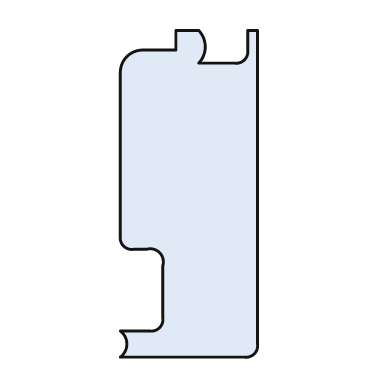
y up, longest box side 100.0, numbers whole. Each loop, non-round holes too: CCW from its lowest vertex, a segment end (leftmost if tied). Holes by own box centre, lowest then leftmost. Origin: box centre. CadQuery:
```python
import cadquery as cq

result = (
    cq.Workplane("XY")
    .moveTo(-21.0, -50.0)
    .lineTo(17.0, -50.0)
    .threePointArc((20.0, -49.0), (21.0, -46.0))
    .lineTo(21.0, 50.0)
    .lineTo(18.0, 50.0)
    .lineTo(18.0, 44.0)
    .threePointArc((17.0, 41.0), (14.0, 40.0))
    .lineTo(3.0, 40.0)
    .threePointArc((5.0, 45.0), (3.0, 50.0))
    .lineTo(-4.0, 50.0)
    .lineTo(-4.0, 44.0)
    .lineTo(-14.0, 44.0)
    .threePointArc((-19.0, 42.0), (-21.0, 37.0))
    .lineTo(-21.0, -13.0)
    .threePointArc((-20.0, -16.0), (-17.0, -17.0))
    .lineTo(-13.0, -17.0)
    .threePointArc((-9.0, -18.0), (-8.0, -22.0))
    .lineTo(-8.0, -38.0)
    .threePointArc((-9.0, -41.0), (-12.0, -42.0))
    .lineTo(-21.0, -42.0)
    .threePointArc((-19.0, -46.0), (-21.0, -50.0))
    .close()
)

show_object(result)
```